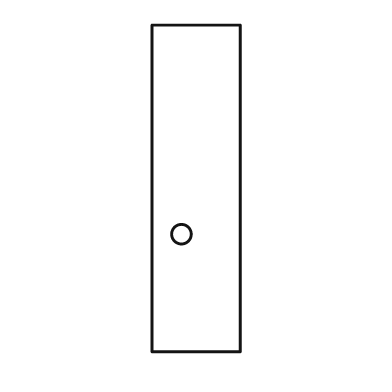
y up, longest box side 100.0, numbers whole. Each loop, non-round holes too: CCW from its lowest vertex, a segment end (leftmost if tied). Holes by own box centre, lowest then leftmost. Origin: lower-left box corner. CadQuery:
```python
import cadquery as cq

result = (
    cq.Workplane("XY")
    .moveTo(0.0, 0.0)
    .lineTo(27.0, 0.0)
    .lineTo(27.0, 100.0)
    .lineTo(0.0, 100.0)
    .close()
    .moveTo(9.0, 36.0)
    .circle(3.0)
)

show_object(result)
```